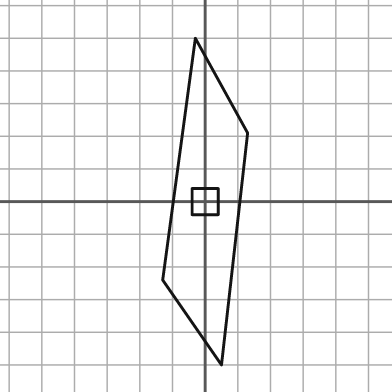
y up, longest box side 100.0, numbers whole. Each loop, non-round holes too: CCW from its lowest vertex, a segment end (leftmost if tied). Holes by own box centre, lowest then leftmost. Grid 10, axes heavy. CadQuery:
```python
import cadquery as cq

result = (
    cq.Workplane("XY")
    .moveTo(5.0, -50.0)
    .lineTo(13.0, 21.0)
    .lineTo(-3.0, 50.0)
    .lineTo(-13.0, -24.0)
    .close()
    .moveTo(-4.0, -4.0)
    .lineTo(4.0, -4.0)
    .lineTo(4.0, 4.0)
    .lineTo(-4.0, 4.0)
    .close()
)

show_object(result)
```